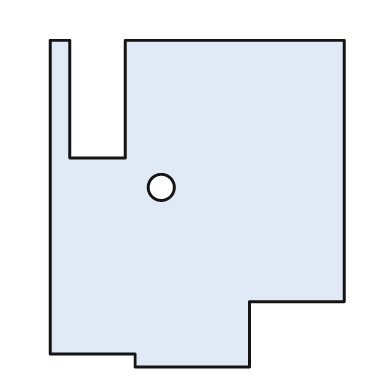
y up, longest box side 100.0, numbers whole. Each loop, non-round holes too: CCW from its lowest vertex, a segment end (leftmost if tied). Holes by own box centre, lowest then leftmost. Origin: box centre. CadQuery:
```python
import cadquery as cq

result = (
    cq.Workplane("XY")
    .moveTo(-19.0, -50.0)
    .lineTo(16.0, -50.0)
    .lineTo(16.0, -30.0)
    .lineTo(45.0, -30.0)
    .lineTo(45.0, 50.0)
    .lineTo(-22.0, 50.0)
    .lineTo(-22.0, 14.0)
    .lineTo(-39.0, 14.0)
    .lineTo(-39.0, 50.0)
    .lineTo(-45.0, 50.0)
    .lineTo(-45.0, -46.0)
    .lineTo(-19.0, -46.0)
    .close()
    .moveTo(-11.0, 5.0)
    .circle(4.0)
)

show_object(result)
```